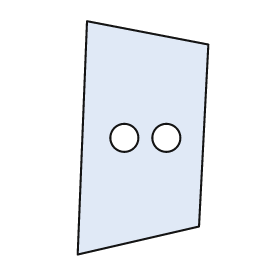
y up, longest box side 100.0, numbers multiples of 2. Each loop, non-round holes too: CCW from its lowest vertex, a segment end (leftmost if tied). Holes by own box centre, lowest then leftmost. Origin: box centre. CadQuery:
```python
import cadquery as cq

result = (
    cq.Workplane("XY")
    .moveTo(-28.0, -50.0)
    .lineTo(24.0, -38.0)
    .lineTo(28.0, 40.0)
    .lineTo(-24.0, 50.0)
    .close()
    .moveTo(-8.0, 0.0)
    .circle(6.0)
    .moveTo(10.0, 0.0)
    .circle(6.0)
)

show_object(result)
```